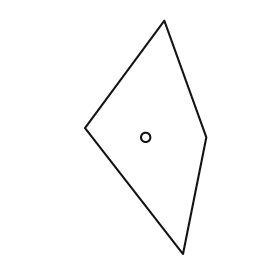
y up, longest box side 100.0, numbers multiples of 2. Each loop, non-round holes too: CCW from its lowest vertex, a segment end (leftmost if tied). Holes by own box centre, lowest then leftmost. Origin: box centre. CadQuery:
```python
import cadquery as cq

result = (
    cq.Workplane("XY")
    .moveTo(16.0, -50.0)
    .lineTo(26.0, 0.0)
    .lineTo(8.0, 50.0)
    .lineTo(-26.0, 4.0)
    .close()
    .moveTo(0.0, 0.0)
    .circle(2.0)
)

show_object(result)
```